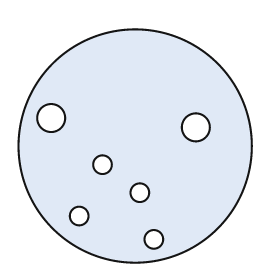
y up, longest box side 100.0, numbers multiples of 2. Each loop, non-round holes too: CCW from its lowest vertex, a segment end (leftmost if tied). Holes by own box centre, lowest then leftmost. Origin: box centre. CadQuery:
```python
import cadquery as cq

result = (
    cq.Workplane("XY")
    .moveTo(0.0, 0.0)
    .circle(50.0)
    .moveTo(8.0, -40.0)
    .circle(4.0)
    .moveTo(-24.0, -30.0)
    .circle(4.0)
    .moveTo(2.0, -20.0)
    .circle(4.0)
    .moveTo(-14.0, -8.0)
    .circle(4.0)
    .moveTo(26.0, 8.0)
    .circle(6.0)
    .moveTo(-36.0, 12.0)
    .circle(6.0)
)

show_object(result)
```